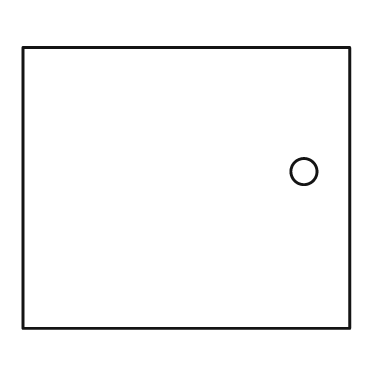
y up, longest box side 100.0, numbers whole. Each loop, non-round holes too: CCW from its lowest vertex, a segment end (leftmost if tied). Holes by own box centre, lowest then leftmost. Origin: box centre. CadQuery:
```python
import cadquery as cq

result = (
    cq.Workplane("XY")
    .moveTo(-50.0, -43.0)
    .lineTo(50.0, -43.0)
    .lineTo(50.0, 43.0)
    .lineTo(-50.0, 43.0)
    .close()
    .moveTo(36.0, 5.0)
    .circle(4.0)
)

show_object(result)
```